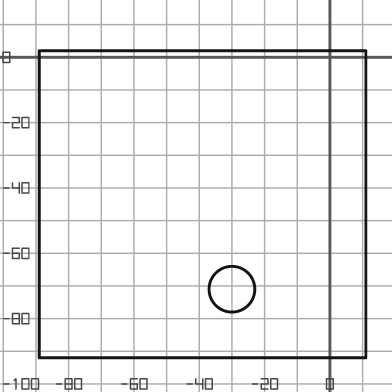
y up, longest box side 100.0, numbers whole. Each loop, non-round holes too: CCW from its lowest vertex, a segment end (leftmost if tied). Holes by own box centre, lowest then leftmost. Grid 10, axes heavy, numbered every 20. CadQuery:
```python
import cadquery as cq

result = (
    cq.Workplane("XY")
    .moveTo(-89.0, -92.0)
    .lineTo(11.0, -92.0)
    .lineTo(11.0, 2.0)
    .lineTo(-89.0, 2.0)
    .close()
    .moveTo(-30.0, -71.0)
    .circle(7.0)
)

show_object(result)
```